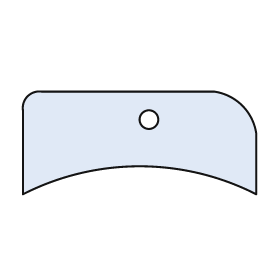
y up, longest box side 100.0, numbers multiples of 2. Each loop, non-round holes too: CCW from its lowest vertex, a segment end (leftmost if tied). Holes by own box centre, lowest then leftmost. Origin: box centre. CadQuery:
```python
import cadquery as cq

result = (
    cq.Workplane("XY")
    .moveTo(-50.0, -22.0)
    .threePointArc((0.0, -10.0), (50.0, -22.0))
    .lineTo(50.0, 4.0)
    .threePointArc((44.0, 16.0), (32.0, 22.0))
    .lineTo(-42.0, 22.0)
    .threePointArc((-48.0, 20.0), (-50.0, 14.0))
    .close()
    .moveTo(4.0, 10.0)
    .circle(4.0)
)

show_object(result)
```